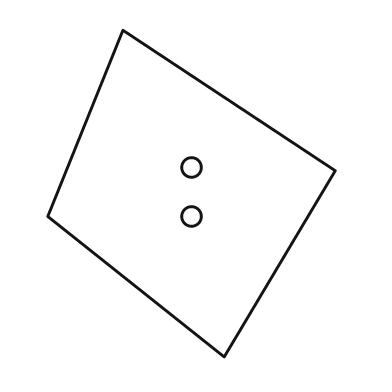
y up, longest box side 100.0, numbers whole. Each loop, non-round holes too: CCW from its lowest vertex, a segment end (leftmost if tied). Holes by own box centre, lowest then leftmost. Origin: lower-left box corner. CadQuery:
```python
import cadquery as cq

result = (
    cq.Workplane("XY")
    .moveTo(54.0, 0.0)
    .lineTo(88.0, 57.0)
    .lineTo(23.0, 100.0)
    .lineTo(0.0, 43.0)
    .close()
    .moveTo(44.0, 43.0)
    .circle(3.0)
    .moveTo(44.0, 58.0)
    .circle(3.0)
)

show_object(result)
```